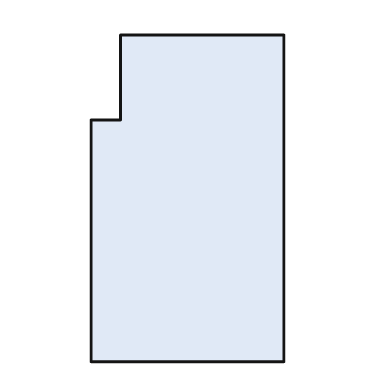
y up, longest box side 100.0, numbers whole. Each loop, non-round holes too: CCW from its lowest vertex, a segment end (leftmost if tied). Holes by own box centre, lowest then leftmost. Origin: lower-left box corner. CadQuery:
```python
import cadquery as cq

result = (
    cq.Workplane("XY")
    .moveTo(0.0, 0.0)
    .lineTo(59.0, 0.0)
    .lineTo(59.0, 100.0)
    .lineTo(9.0, 100.0)
    .lineTo(9.0, 74.0)
    .lineTo(0.0, 74.0)
    .close()
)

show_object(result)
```